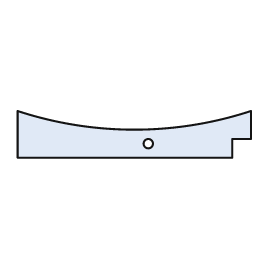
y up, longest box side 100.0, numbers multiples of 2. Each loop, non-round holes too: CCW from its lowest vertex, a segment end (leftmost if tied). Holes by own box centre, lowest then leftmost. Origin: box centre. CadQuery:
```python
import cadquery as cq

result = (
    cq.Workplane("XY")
    .moveTo(-50.0, -10.0)
    .lineTo(42.0, -10.0)
    .lineTo(42.0, -2.0)
    .lineTo(50.0, -2.0)
    .lineTo(50.0, 10.0)
    .threePointArc((0.0, 2.0), (-50.0, 10.0))
    .close()
    .moveTo(6.0, -4.0)
    .circle(2.0)
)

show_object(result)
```